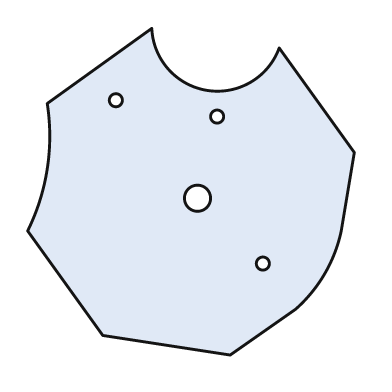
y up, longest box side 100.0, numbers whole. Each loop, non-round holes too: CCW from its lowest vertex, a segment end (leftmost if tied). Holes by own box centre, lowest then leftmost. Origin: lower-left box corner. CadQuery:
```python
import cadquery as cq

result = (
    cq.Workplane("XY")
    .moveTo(62.0, 0.0)
    .lineTo(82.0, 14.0)
    .threePointArc((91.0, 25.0), (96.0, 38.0))
    .lineTo(100.0, 62.0)
    .lineTo(77.0, 94.0)
    .threePointArc((55.0, 81.0), (38.0, 100.0))
    .lineTo(6.0, 77.0)
    .threePointArc((6.0, 57.0), (0.0, 38.0))
    .lineTo(23.0, 6.0)
    .close()
    .moveTo(72.0, 28.0)
    .circle(2.0)
    .moveTo(52.0, 48.0)
    .circle(4.0)
    .moveTo(58.0, 73.0)
    .circle(2.0)
    .moveTo(27.0, 78.0)
    .circle(2.0)
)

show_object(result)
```